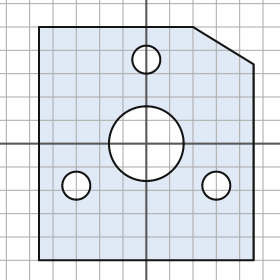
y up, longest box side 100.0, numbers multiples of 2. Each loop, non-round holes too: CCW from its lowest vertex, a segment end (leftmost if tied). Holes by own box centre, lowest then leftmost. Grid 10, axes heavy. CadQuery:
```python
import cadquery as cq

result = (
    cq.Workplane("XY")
    .moveTo(-46.0, -50.0)
    .lineTo(46.0, -50.0)
    .lineTo(46.0, 34.0)
    .lineTo(20.0, 50.0)
    .lineTo(-46.0, 50.0)
    .close()
    .moveTo(-30.0, -18.0)
    .circle(6.0)
    .moveTo(30.0, -18.0)
    .circle(6.0)
    .moveTo(0.0, 0.0)
    .circle(16.0)
    .moveTo(0.0, 36.0)
    .circle(6.0)
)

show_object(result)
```